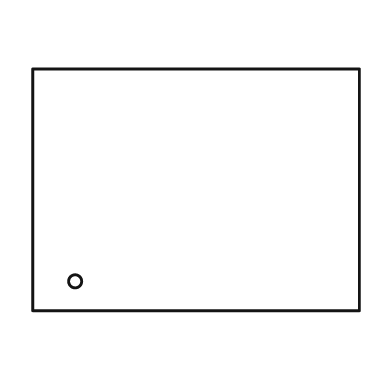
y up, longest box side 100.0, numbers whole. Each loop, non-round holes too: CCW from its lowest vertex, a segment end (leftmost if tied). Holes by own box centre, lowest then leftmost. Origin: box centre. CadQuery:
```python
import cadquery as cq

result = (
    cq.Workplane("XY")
    .moveTo(-50.0, -37.0)
    .lineTo(50.0, -37.0)
    .lineTo(50.0, 37.0)
    .lineTo(-50.0, 37.0)
    .close()
    .moveTo(-37.0, -28.0)
    .circle(2.0)
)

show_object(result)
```